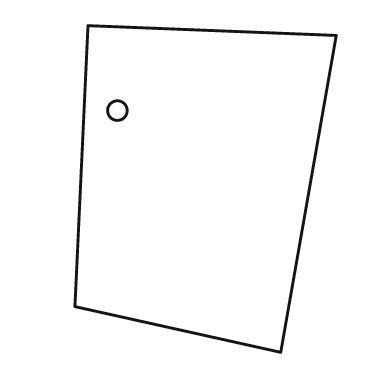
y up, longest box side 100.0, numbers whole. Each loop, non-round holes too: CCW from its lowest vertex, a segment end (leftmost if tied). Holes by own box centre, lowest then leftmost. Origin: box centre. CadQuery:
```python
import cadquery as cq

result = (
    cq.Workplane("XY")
    .moveTo(23.0, -50.0)
    .lineTo(40.0, 47.0)
    .lineTo(-36.0, 50.0)
    .lineTo(-40.0, -36.0)
    .close()
    .moveTo(-27.0, 24.0)
    .circle(3.0)
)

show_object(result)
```